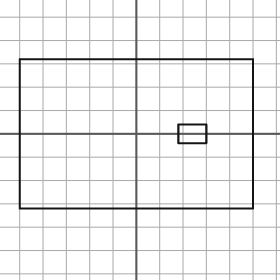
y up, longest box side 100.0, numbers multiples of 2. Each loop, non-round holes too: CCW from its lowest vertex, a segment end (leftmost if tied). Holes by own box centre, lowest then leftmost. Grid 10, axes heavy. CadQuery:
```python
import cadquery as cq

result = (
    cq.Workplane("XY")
    .moveTo(-50.0, -32.0)
    .lineTo(50.0, -32.0)
    .lineTo(50.0, 32.0)
    .lineTo(-50.0, 32.0)
    .close()
    .moveTo(18.0, -4.0)
    .lineTo(30.0, -4.0)
    .lineTo(30.0, 4.0)
    .lineTo(18.0, 4.0)
    .close()
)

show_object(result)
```